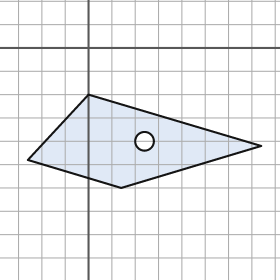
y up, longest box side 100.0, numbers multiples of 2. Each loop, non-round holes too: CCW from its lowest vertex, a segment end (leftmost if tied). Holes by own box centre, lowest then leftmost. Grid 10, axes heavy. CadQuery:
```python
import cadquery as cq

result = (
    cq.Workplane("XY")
    .moveTo(14.0, -60.0)
    .lineTo(74.0, -42.0)
    .lineTo(0.0, -20.0)
    .lineTo(-26.0, -48.0)
    .close()
    .moveTo(24.0, -40.0)
    .circle(4.0)
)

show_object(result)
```